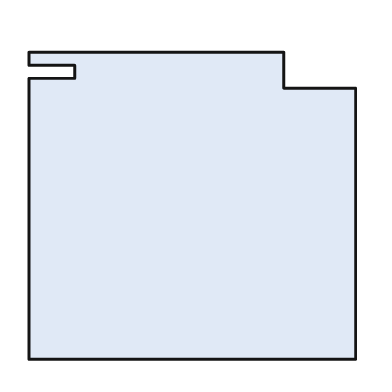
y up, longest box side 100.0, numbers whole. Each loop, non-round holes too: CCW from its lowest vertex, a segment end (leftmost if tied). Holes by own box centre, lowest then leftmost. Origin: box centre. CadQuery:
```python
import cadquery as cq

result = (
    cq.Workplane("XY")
    .moveTo(-50.0, -47.0)
    .lineTo(50.0, -47.0)
    .lineTo(50.0, 36.0)
    .lineTo(28.0, 36.0)
    .lineTo(28.0, 47.0)
    .lineTo(-50.0, 47.0)
    .lineTo(-50.0, 43.0)
    .lineTo(-36.0, 43.0)
    .lineTo(-36.0, 39.0)
    .lineTo(-50.0, 39.0)
    .close()
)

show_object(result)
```